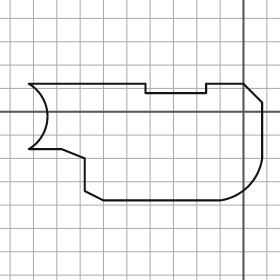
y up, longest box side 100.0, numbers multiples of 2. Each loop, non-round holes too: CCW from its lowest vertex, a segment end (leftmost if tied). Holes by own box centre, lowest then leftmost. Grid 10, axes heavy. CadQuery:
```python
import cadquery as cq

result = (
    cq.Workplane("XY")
    .moveTo(-60.0, -38.0)
    .lineTo(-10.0, -38.0)
    .threePointArc((2.0, -32.0), (8.0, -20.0))
    .lineTo(8.0, 4.0)
    .lineTo(0.0, 12.0)
    .lineTo(-16.0, 12.0)
    .lineTo(-16.0, 8.0)
    .lineTo(-42.0, 8.0)
    .lineTo(-42.0, 12.0)
    .lineTo(-92.0, 12.0)
    .threePointArc((-84.0, -2.0), (-92.0, -16.0))
    .lineTo(-78.0, -16.0)
    .lineTo(-68.0, -20.0)
    .lineTo(-68.0, -34.0)
    .close()
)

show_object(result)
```